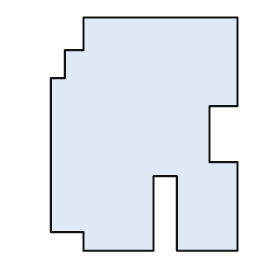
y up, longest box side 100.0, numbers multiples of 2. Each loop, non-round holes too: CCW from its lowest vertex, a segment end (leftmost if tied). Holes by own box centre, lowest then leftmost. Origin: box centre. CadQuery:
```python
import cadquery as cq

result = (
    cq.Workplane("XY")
    .moveTo(-26.0, -50.0)
    .lineTo(4.0, -50.0)
    .lineTo(4.0, -18.0)
    .lineTo(14.0, -18.0)
    .lineTo(14.0, -50.0)
    .lineTo(40.0, -50.0)
    .lineTo(40.0, -12.0)
    .lineTo(28.0, -12.0)
    .lineTo(28.0, 12.0)
    .lineTo(40.0, 12.0)
    .lineTo(40.0, 50.0)
    .lineTo(-26.0, 50.0)
    .lineTo(-26.0, 36.0)
    .lineTo(-34.0, 36.0)
    .lineTo(-34.0, 24.0)
    .lineTo(-40.0, 24.0)
    .lineTo(-40.0, -42.0)
    .lineTo(-26.0, -42.0)
    .close()
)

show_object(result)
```